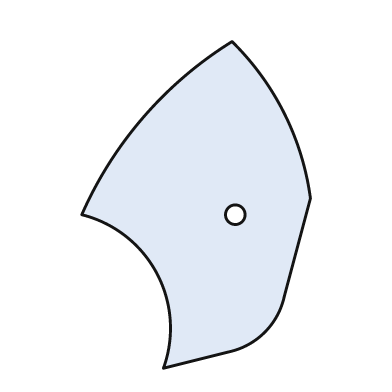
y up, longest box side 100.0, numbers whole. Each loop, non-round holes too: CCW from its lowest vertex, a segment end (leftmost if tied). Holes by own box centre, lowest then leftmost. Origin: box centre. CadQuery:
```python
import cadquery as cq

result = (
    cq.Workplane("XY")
    .moveTo(-10.0, -50.0)
    .lineTo(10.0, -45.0)
    .threePointArc((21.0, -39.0), (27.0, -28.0))
    .lineTo(35.0, 2.0)
    .threePointArc((27.0, 28.0), (11.0, 50.0))
    .threePointArc((-16.0, 27.0), (-35.0, -3.0))
    .threePointArc((-12.0, -21.0), (-10.0, -50.0))
    .close()
    .moveTo(12.0, -3.0)
    .circle(3.0)
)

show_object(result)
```